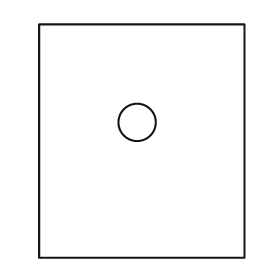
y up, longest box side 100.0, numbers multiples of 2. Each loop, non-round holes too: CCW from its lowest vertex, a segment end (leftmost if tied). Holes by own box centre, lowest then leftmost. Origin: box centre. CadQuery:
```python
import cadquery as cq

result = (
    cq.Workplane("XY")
    .moveTo(-44.0, -50.0)
    .lineTo(44.0, -50.0)
    .lineTo(44.0, 50.0)
    .lineTo(-44.0, 50.0)
    .close()
    .moveTo(-2.0, 8.0)
    .circle(8.0)
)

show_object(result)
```